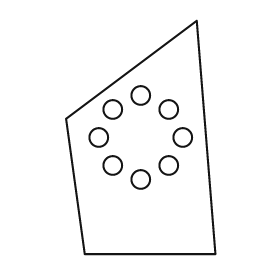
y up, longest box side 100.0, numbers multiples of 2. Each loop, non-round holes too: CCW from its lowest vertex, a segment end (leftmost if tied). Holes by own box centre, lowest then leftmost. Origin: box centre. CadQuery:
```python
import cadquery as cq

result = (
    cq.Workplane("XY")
    .moveTo(-24.0, -50.0)
    .lineTo(32.0, -50.0)
    .lineTo(24.0, 50.0)
    .lineTo(-32.0, 8.0)
    .close()
    .moveTo(0.0, -18.0)
    .circle(4.0)
    .moveTo(-12.0, -12.0)
    .circle(4.0)
    .moveTo(12.0, -12.0)
    .circle(4.0)
    .moveTo(-18.0, 0.0)
    .circle(4.0)
    .moveTo(18.0, 0.0)
    .circle(4.0)
    .moveTo(-12.0, 12.0)
    .circle(4.0)
    .moveTo(12.0, 12.0)
    .circle(4.0)
    .moveTo(0.0, 18.0)
    .circle(4.0)
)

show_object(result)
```